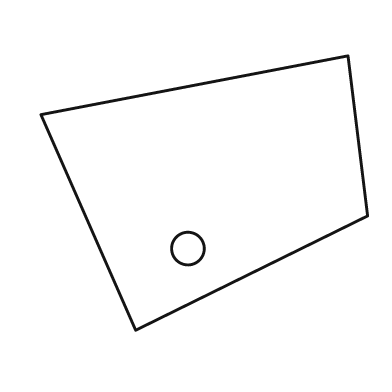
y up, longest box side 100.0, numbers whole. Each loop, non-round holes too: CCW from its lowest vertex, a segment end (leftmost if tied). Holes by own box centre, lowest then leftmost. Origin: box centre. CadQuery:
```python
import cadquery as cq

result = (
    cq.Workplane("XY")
    .moveTo(-21.0, -42.0)
    .lineTo(50.0, -7.0)
    .lineTo(44.0, 42.0)
    .lineTo(-50.0, 24.0)
    .close()
    .moveTo(-5.0, -17.0)
    .circle(5.0)
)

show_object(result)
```